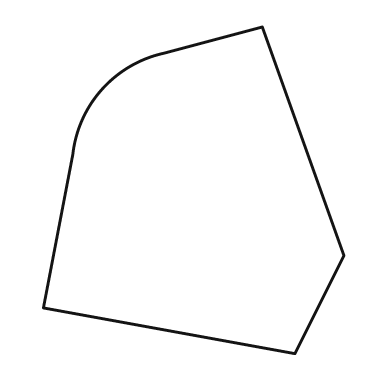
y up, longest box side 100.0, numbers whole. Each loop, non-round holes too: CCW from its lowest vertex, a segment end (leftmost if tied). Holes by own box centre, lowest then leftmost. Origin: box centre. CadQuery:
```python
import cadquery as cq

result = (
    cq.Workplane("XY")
    .moveTo(31.0, -50.0)
    .lineTo(46.0, -20.0)
    .lineTo(21.0, 50.0)
    .lineTo(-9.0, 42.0)
    .threePointArc((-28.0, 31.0), (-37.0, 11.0))
    .lineTo(-46.0, -36.0)
    .close()
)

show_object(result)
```